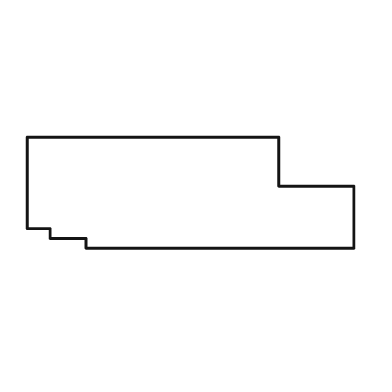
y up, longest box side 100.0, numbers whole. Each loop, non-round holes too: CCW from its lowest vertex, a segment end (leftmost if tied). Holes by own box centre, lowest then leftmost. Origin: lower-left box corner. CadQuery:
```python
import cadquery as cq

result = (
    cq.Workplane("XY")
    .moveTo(18.0, 0.0)
    .lineTo(100.0, 0.0)
    .lineTo(100.0, 19.0)
    .lineTo(77.0, 19.0)
    .lineTo(77.0, 34.0)
    .lineTo(0.0, 34.0)
    .lineTo(0.0, 6.0)
    .lineTo(7.0, 6.0)
    .lineTo(7.0, 3.0)
    .lineTo(18.0, 3.0)
    .close()
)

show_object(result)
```